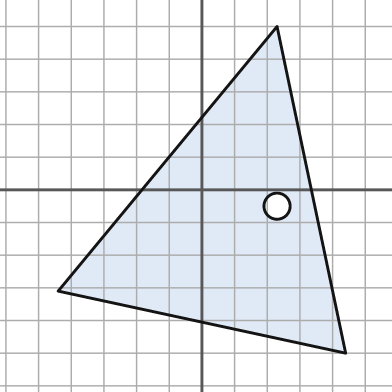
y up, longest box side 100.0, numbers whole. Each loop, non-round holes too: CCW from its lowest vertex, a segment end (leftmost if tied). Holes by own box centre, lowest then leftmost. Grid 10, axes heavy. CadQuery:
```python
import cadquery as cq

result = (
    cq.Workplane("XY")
    .moveTo(44.0, -50.0)
    .lineTo(23.0, 50.0)
    .lineTo(-44.0, -31.0)
    .close()
    .moveTo(23.0, -5.0)
    .circle(4.0)
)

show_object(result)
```